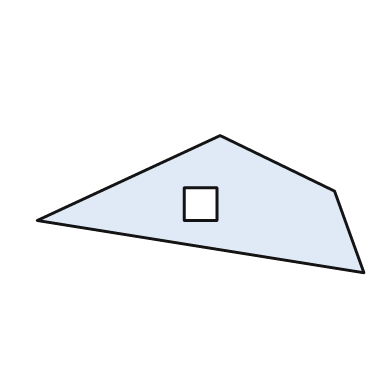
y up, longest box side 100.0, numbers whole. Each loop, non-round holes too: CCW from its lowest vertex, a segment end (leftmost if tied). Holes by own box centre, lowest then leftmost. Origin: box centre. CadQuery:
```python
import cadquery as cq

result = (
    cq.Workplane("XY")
    .moveTo(50.0, -21.0)
    .lineTo(41.0, 4.0)
    .lineTo(6.0, 21.0)
    .lineTo(-50.0, -5.0)
    .close()
    .moveTo(-5.0, -5.0)
    .lineTo(5.0, -5.0)
    .lineTo(5.0, 5.0)
    .lineTo(-5.0, 5.0)
    .close()
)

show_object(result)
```